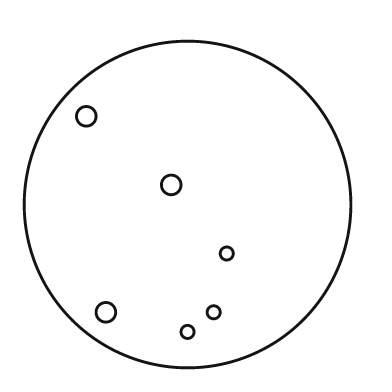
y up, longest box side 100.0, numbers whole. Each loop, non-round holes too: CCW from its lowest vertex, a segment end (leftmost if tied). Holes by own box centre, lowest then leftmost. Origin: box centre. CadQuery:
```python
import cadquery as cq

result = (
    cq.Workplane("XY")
    .moveTo(0.0, 0.0)
    .circle(50.0)
    .moveTo(0.0, -39.0)
    .circle(2.0)
    .moveTo(-25.0, -33.0)
    .circle(3.0)
    .moveTo(8.0, -33.0)
    .circle(2.0)
    .moveTo(12.0, -15.0)
    .circle(2.0)
    .moveTo(-5.0, 6.0)
    .circle(3.0)
    .moveTo(-31.0, 27.0)
    .circle(3.0)
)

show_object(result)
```